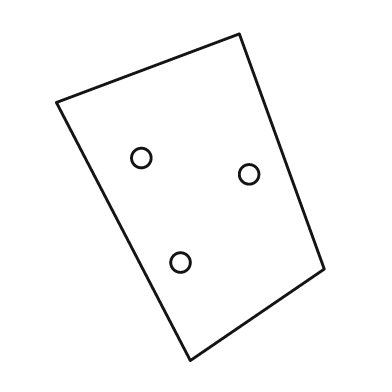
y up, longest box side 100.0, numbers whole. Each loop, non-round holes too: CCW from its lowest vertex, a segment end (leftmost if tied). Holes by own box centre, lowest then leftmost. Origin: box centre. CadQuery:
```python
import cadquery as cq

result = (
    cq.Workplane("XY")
    .moveTo(0.0, -50.0)
    .lineTo(41.0, -22.0)
    .lineTo(15.0, 50.0)
    .lineTo(-41.0, 29.0)
    .close()
    .moveTo(-3.0, -20.0)
    .circle(3.0)
    .moveTo(18.0, 7.0)
    .circle(3.0)
    .moveTo(-15.0, 12.0)
    .circle(3.0)
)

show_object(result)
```